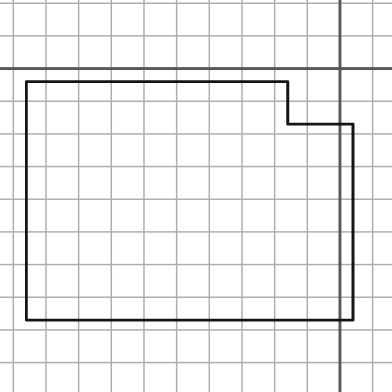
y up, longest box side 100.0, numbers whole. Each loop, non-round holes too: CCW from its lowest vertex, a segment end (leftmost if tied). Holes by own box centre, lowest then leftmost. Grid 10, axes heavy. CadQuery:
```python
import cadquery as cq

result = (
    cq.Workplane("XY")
    .moveTo(-96.0, -77.0)
    .lineTo(4.0, -77.0)
    .lineTo(4.0, -17.0)
    .lineTo(-16.0, -17.0)
    .lineTo(-16.0, -4.0)
    .lineTo(-96.0, -4.0)
    .close()
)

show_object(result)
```